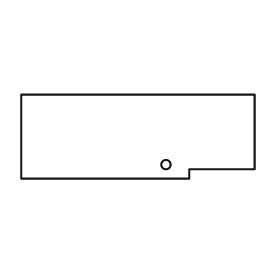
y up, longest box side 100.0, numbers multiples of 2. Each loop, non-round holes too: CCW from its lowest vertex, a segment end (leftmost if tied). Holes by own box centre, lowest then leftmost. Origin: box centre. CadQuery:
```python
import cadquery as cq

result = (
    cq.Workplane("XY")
    .moveTo(-50.0, -18.0)
    .lineTo(22.0, -18.0)
    .lineTo(22.0, -14.0)
    .lineTo(50.0, -14.0)
    .lineTo(50.0, 18.0)
    .lineTo(-50.0, 18.0)
    .close()
    .moveTo(12.0, -12.0)
    .circle(2.0)
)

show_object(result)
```